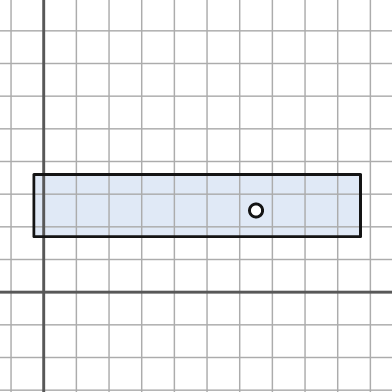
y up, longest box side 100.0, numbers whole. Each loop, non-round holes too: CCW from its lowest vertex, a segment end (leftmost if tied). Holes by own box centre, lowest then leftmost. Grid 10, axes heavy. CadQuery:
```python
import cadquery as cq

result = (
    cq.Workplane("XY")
    .moveTo(-3.0, 17.0)
    .lineTo(97.0, 17.0)
    .lineTo(97.0, 36.0)
    .lineTo(-3.0, 36.0)
    .close()
    .moveTo(65.0, 25.0)
    .circle(2.0)
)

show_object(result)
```